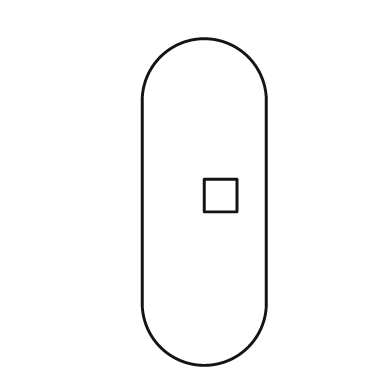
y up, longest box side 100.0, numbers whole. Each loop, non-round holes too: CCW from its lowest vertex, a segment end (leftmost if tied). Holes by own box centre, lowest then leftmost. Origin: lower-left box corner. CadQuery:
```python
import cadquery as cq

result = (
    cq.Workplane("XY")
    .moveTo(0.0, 19.0)
    .threePointArc((19.0, 0.0), (38.0, 19.0))
    .lineTo(38.0, 81.0)
    .threePointArc((19.0, 100.0), (0.0, 81.0))
    .close()
    .moveTo(19.0, 47.0)
    .lineTo(29.0, 47.0)
    .lineTo(29.0, 57.0)
    .lineTo(19.0, 57.0)
    .close()
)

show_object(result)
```